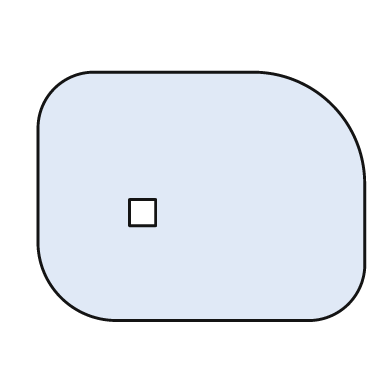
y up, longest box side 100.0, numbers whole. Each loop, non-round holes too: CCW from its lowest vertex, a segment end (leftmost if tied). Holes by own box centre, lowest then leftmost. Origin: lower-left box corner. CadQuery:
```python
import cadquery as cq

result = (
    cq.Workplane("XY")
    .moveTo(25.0, 0.0)
    .lineTo(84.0, 0.0)
    .threePointArc((95.0, 5.0), (100.0, 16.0))
    .lineTo(100.0, 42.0)
    .threePointArc((90.0, 66.0), (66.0, 76.0))
    .lineTo(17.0, 76.0)
    .threePointArc((5.0, 71.0), (0.0, 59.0))
    .lineTo(0.0, 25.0)
    .threePointArc((7.0, 7.0), (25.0, 0.0))
    .close()
    .moveTo(28.0, 29.0)
    .lineTo(36.0, 29.0)
    .lineTo(36.0, 37.0)
    .lineTo(28.0, 37.0)
    .close()
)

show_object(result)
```